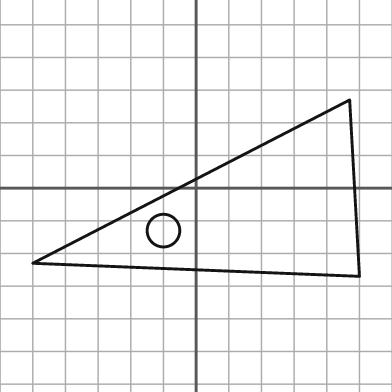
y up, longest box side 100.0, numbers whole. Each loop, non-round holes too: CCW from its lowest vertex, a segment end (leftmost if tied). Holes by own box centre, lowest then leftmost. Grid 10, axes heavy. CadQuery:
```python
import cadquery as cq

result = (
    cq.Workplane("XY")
    .moveTo(50.0, -27.0)
    .lineTo(47.0, 27.0)
    .lineTo(-50.0, -23.0)
    .close()
    .moveTo(-10.0, -13.0)
    .circle(5.0)
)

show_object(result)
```